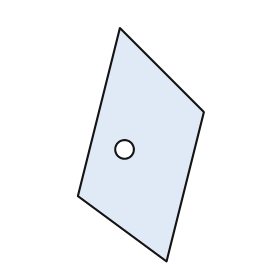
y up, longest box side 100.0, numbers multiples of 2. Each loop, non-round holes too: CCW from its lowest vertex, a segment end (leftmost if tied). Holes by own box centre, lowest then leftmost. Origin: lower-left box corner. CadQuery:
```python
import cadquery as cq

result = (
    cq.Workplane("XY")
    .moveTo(38.0, 0.0)
    .lineTo(54.0, 64.0)
    .lineTo(18.0, 100.0)
    .lineTo(0.0, 28.0)
    .close()
    .moveTo(20.0, 48.0)
    .circle(4.0)
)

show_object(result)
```